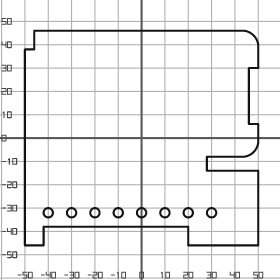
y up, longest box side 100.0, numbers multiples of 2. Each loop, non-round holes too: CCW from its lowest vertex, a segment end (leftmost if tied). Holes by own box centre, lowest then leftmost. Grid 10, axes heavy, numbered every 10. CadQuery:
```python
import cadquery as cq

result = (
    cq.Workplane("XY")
    .moveTo(-50.0, -46.0)
    .lineTo(-42.0, -46.0)
    .lineTo(-42.0, -38.0)
    .lineTo(20.0, -38.0)
    .lineTo(20.0, -46.0)
    .lineTo(50.0, -46.0)
    .lineTo(50.0, -14.0)
    .lineTo(28.0, -14.0)
    .lineTo(28.0, -8.0)
    .lineTo(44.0, -8.0)
    .threePointArc((48.0, -6.0), (50.0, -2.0))
    .lineTo(50.0, 6.0)
    .lineTo(46.0, 6.0)
    .lineTo(46.0, 30.0)
    .lineTo(50.0, 30.0)
    .lineTo(50.0, 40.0)
    .threePointArc((48.0, 44.0), (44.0, 46.0))
    .lineTo(-46.0, 46.0)
    .lineTo(-46.0, 38.0)
    .lineTo(-50.0, 38.0)
    .close()
    .moveTo(-40.0, -32.0)
    .circle(2.0)
    .moveTo(-30.0, -32.0)
    .circle(2.0)
    .moveTo(-20.0, -32.0)
    .circle(2.0)
    .moveTo(-10.0, -32.0)
    .circle(2.0)
    .moveTo(0.0, -32.0)
    .circle(2.0)
    .moveTo(10.0, -32.0)
    .circle(2.0)
    .moveTo(20.0, -32.0)
    .circle(2.0)
    .moveTo(30.0, -32.0)
    .circle(2.0)
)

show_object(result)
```